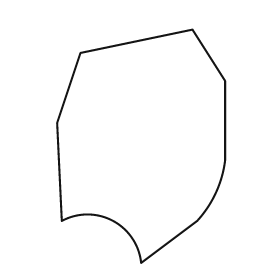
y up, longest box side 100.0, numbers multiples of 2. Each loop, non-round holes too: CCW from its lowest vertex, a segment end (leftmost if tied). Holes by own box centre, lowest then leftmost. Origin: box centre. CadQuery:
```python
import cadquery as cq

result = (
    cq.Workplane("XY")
    .moveTo(0.0, -50.0)
    .lineTo(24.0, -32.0)
    .threePointArc((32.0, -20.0), (36.0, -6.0))
    .lineTo(36.0, 28.0)
    .lineTo(22.0, 50.0)
    .lineTo(-26.0, 40.0)
    .lineTo(-36.0, 10.0)
    .lineTo(-34.0, -32.0)
    .threePointArc((-12.0, -32.0), (0.0, -50.0))
    .close()
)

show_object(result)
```